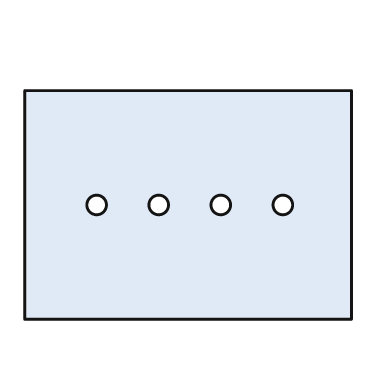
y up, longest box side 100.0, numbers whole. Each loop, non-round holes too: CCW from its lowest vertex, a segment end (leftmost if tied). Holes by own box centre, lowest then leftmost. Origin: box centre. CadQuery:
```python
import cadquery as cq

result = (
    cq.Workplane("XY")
    .moveTo(-50.0, -35.0)
    .lineTo(50.0, -35.0)
    .lineTo(50.0, 35.0)
    .lineTo(-50.0, 35.0)
    .close()
    .moveTo(-28.0, 0.0)
    .circle(3.0)
    .moveTo(-9.0, 0.0)
    .circle(3.0)
    .moveTo(10.0, 0.0)
    .circle(3.0)
    .moveTo(29.0, 0.0)
    .circle(3.0)
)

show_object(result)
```